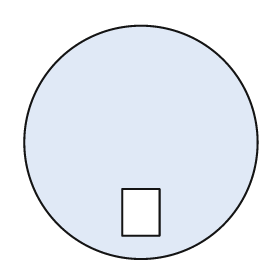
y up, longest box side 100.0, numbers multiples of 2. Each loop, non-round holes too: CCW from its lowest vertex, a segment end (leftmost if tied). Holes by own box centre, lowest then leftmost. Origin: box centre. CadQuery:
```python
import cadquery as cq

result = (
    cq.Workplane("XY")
    .moveTo(0.0, 0.0)
    .circle(50.0)
    .moveTo(-8.0, -40.0)
    .lineTo(8.0, -40.0)
    .lineTo(8.0, -20.0)
    .lineTo(-8.0, -20.0)
    .close()
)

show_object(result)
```